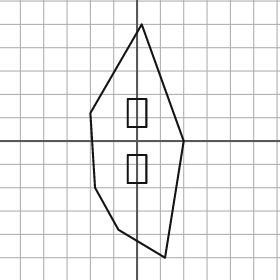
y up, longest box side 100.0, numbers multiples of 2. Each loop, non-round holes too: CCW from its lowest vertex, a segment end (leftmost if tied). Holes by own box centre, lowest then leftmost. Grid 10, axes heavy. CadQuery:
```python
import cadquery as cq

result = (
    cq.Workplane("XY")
    .moveTo(12.0, -50.0)
    .lineTo(20.0, 0.0)
    .lineTo(2.0, 50.0)
    .lineTo(-20.0, 12.0)
    .lineTo(-18.0, -20.0)
    .lineTo(-8.0, -38.0)
    .close()
    .moveTo(-4.0, -18.0)
    .lineTo(4.0, -18.0)
    .lineTo(4.0, -6.0)
    .lineTo(-4.0, -6.0)
    .close()
    .moveTo(-4.0, 6.0)
    .lineTo(4.0, 6.0)
    .lineTo(4.0, 18.0)
    .lineTo(-4.0, 18.0)
    .close()
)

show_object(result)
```